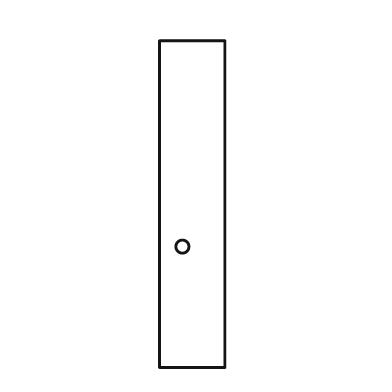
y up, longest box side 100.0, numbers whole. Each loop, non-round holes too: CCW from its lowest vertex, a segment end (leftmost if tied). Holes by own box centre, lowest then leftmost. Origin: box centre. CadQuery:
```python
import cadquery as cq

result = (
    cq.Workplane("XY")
    .moveTo(-10.0, -50.0)
    .lineTo(10.0, -50.0)
    .lineTo(10.0, 50.0)
    .lineTo(-10.0, 50.0)
    .close()
    .moveTo(-3.0, -13.0)
    .circle(2.0)
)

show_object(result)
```